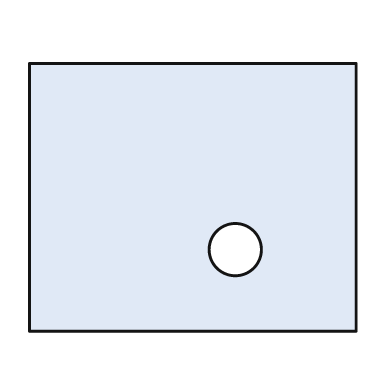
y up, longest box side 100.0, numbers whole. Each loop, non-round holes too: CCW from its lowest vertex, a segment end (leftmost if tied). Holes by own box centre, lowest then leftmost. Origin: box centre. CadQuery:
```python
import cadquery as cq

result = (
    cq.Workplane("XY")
    .moveTo(-50.0, -41.0)
    .lineTo(50.0, -41.0)
    .lineTo(50.0, 41.0)
    .lineTo(-50.0, 41.0)
    .close()
    .moveTo(13.0, -16.0)
    .circle(8.0)
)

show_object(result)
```